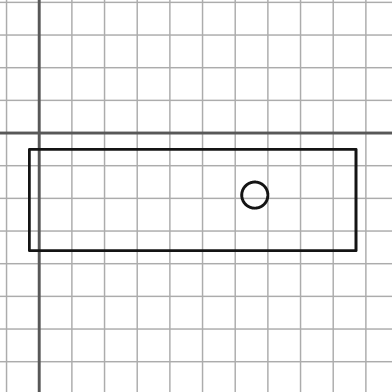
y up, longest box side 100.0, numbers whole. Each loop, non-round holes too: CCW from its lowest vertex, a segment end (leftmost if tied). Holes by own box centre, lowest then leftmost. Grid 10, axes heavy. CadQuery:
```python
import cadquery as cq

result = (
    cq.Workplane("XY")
    .moveTo(-3.0, -36.0)
    .lineTo(97.0, -36.0)
    .lineTo(97.0, -5.0)
    .lineTo(-3.0, -5.0)
    .close()
    .moveTo(66.0, -19.0)
    .circle(4.0)
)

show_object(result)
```